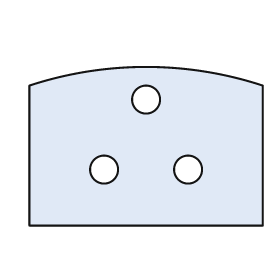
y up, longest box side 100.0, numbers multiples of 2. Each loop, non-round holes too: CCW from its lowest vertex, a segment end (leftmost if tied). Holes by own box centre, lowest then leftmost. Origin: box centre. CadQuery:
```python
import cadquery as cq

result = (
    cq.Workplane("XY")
    .moveTo(-50.0, -34.0)
    .lineTo(50.0, -34.0)
    .lineTo(50.0, 26.0)
    .threePointArc((0.0, 34.0), (-50.0, 26.0))
    .close()
    .moveTo(-18.0, -10.0)
    .circle(6.0)
    .moveTo(18.0, -10.0)
    .circle(6.0)
    .moveTo(0.0, 20.0)
    .circle(6.0)
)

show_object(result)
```